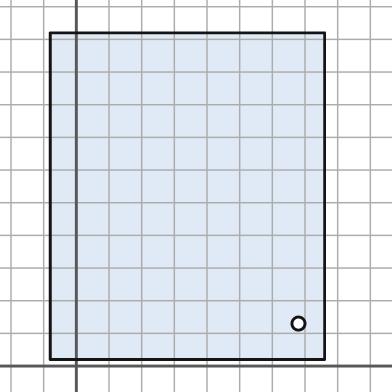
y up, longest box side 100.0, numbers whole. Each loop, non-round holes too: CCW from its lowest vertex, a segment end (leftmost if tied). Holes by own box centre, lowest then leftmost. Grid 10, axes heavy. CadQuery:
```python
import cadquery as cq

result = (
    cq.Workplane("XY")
    .moveTo(-8.0, 2.0)
    .lineTo(76.0, 2.0)
    .lineTo(76.0, 102.0)
    .lineTo(-8.0, 102.0)
    .close()
    .moveTo(68.0, 13.0)
    .circle(2.0)
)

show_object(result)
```